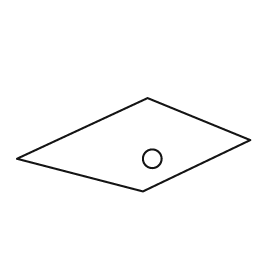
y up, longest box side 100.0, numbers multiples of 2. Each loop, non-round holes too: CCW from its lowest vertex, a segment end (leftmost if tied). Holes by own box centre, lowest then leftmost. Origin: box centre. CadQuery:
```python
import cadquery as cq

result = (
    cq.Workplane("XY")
    .moveTo(4.0, -20.0)
    .lineTo(50.0, 2.0)
    .lineTo(6.0, 20.0)
    .lineTo(-50.0, -6.0)
    .close()
    .moveTo(8.0, -6.0)
    .circle(4.0)
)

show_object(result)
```